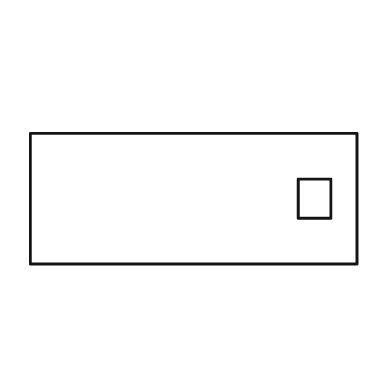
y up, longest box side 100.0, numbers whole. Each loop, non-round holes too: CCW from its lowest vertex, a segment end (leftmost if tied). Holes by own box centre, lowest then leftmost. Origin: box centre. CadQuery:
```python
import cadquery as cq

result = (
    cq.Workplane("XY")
    .moveTo(-50.0, -20.0)
    .lineTo(50.0, -20.0)
    .lineTo(50.0, 20.0)
    .lineTo(-50.0, 20.0)
    .close()
    .moveTo(32.0, -6.0)
    .lineTo(42.0, -6.0)
    .lineTo(42.0, 6.0)
    .lineTo(32.0, 6.0)
    .close()
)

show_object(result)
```